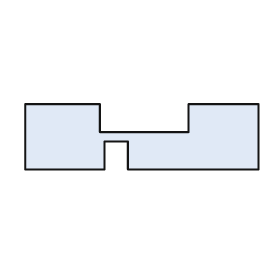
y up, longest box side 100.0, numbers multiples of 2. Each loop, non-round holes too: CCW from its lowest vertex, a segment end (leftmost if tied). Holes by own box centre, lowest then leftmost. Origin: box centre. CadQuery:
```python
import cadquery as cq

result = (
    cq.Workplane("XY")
    .moveTo(-50.0, -14.0)
    .lineTo(-16.0, -14.0)
    .lineTo(-16.0, -2.0)
    .lineTo(-6.0, -2.0)
    .lineTo(-6.0, -14.0)
    .lineTo(50.0, -14.0)
    .lineTo(50.0, 14.0)
    .lineTo(20.0, 14.0)
    .lineTo(20.0, 2.0)
    .lineTo(-18.0, 2.0)
    .lineTo(-18.0, 14.0)
    .lineTo(-50.0, 14.0)
    .close()
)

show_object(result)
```